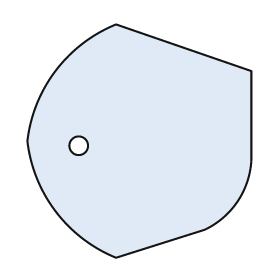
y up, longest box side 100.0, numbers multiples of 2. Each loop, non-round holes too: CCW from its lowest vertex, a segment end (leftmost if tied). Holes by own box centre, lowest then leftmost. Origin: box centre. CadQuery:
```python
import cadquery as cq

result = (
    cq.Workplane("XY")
    .moveTo(-10.0, -50.0)
    .lineTo(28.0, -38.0)
    .threePointArc((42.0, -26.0), (48.0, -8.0))
    .lineTo(48.0, 30.0)
    .lineTo(-10.0, 50.0)
    .threePointArc((-36.0, 30.0), (-48.0, 0.0))
    .threePointArc((-36.0, -30.0), (-10.0, -50.0))
    .close()
    .moveTo(-26.0, -2.0)
    .circle(4.0)
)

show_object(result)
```